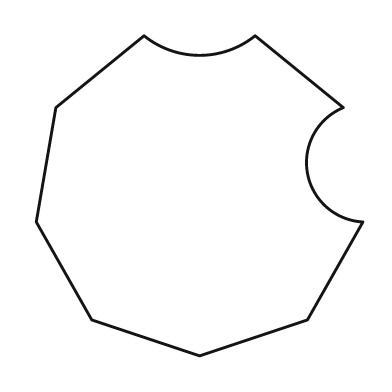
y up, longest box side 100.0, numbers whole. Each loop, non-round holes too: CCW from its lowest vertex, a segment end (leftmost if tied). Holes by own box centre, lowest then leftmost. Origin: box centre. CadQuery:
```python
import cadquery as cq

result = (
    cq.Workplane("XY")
    .moveTo(0.0, -49.0)
    .lineTo(33.0, -38.0)
    .lineTo(50.0, -8.0)
    .threePointArc((33.0, 7.0), (44.0, 27.0))
    .lineTo(17.0, 49.0)
    .threePointArc((0.0, 43.0), (-17.0, 49.0))
    .lineTo(-44.0, 27.0)
    .lineTo(-50.0, -8.0)
    .lineTo(-33.0, -38.0)
    .close()
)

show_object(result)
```